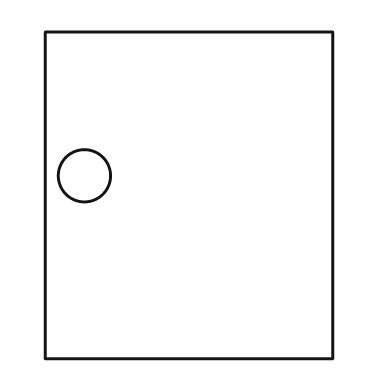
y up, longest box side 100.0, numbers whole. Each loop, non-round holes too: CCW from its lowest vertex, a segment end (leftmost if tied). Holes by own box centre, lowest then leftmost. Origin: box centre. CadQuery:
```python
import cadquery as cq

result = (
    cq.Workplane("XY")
    .moveTo(-44.0, -50.0)
    .lineTo(44.0, -50.0)
    .lineTo(44.0, 50.0)
    .lineTo(-44.0, 50.0)
    .close()
    .moveTo(-32.0, 6.0)
    .circle(8.0)
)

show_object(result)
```